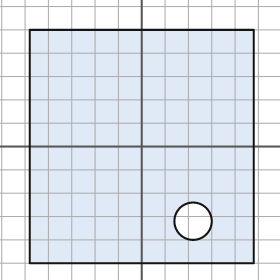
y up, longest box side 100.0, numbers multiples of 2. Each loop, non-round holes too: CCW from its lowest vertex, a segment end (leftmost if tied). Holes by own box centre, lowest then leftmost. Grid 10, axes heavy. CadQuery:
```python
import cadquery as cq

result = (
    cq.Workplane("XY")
    .moveTo(-48.0, -50.0)
    .lineTo(48.0, -50.0)
    .lineTo(48.0, 50.0)
    .lineTo(-48.0, 50.0)
    .close()
    .moveTo(22.0, -32.0)
    .circle(8.0)
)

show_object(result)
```